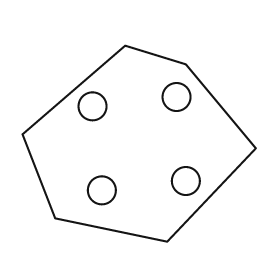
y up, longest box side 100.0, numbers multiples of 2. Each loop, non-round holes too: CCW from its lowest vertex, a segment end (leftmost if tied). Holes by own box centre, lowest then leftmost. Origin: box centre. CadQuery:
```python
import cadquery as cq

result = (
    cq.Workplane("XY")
    .moveTo(12.0, -42.0)
    .lineTo(50.0, -2.0)
    .lineTo(20.0, 34.0)
    .lineTo(-6.0, 42.0)
    .lineTo(-50.0, 4.0)
    .lineTo(-36.0, -32.0)
    .close()
    .moveTo(-16.0, -20.0)
    .circle(6.0)
    .moveTo(20.0, -16.0)
    .circle(6.0)
    .moveTo(-20.0, 16.0)
    .circle(6.0)
    .moveTo(16.0, 20.0)
    .circle(6.0)
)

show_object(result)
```